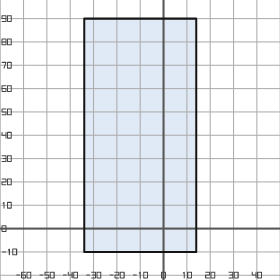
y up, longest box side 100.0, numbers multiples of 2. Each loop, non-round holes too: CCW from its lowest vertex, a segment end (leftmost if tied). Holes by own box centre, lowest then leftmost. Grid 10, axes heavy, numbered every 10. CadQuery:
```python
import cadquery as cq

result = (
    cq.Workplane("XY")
    .moveTo(-34.0, -10.0)
    .lineTo(14.0, -10.0)
    .lineTo(14.0, 90.0)
    .lineTo(-34.0, 90.0)
    .close()
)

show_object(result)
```